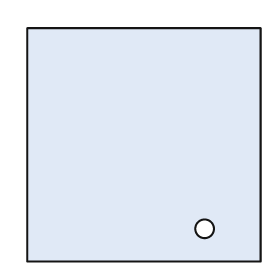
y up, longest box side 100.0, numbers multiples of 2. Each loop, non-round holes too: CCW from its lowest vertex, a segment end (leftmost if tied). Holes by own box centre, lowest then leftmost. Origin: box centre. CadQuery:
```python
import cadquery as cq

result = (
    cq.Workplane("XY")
    .moveTo(-50.0, -50.0)
    .lineTo(50.0, -50.0)
    .lineTo(50.0, 50.0)
    .lineTo(-50.0, 50.0)
    .close()
    .moveTo(26.0, -36.0)
    .circle(4.0)
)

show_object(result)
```